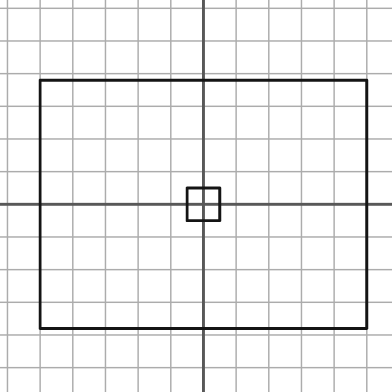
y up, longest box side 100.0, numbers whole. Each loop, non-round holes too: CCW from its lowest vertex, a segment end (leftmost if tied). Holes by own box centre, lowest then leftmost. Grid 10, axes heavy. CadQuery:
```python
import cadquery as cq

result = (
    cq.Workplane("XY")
    .moveTo(-50.0, -38.0)
    .lineTo(50.0, -38.0)
    .lineTo(50.0, 38.0)
    .lineTo(-50.0, 38.0)
    .close()
    .moveTo(-5.0, -5.0)
    .lineTo(5.0, -5.0)
    .lineTo(5.0, 5.0)
    .lineTo(-5.0, 5.0)
    .close()
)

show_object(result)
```